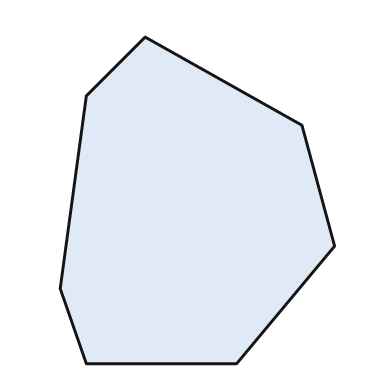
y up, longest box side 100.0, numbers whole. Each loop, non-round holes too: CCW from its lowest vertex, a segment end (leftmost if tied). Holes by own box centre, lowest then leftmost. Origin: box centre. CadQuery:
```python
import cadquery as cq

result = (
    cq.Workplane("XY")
    .moveTo(-34.0, -50.0)
    .lineTo(12.0, -50.0)
    .lineTo(42.0, -14.0)
    .lineTo(32.0, 23.0)
    .lineTo(-16.0, 50.0)
    .lineTo(-34.0, 32.0)
    .lineTo(-42.0, -27.0)
    .close()
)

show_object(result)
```